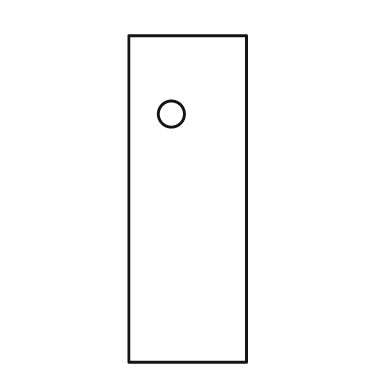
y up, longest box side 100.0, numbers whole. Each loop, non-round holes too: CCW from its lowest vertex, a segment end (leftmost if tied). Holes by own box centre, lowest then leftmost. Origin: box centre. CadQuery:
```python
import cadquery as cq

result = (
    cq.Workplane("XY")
    .moveTo(-18.0, -50.0)
    .lineTo(18.0, -50.0)
    .lineTo(18.0, 50.0)
    .lineTo(-18.0, 50.0)
    .close()
    .moveTo(-5.0, 26.0)
    .circle(4.0)
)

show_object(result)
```